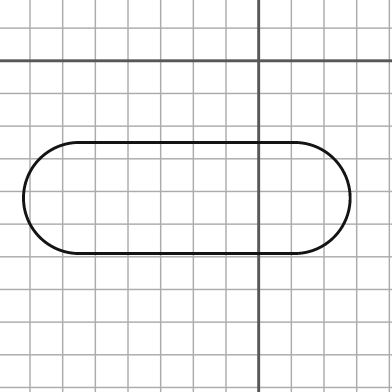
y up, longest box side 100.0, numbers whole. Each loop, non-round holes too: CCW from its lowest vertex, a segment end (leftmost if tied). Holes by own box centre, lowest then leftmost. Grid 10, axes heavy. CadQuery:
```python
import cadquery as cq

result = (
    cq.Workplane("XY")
    .moveTo(-55.0, -59.0)
    .lineTo(11.0, -59.0)
    .threePointArc((28.0, -42.0), (11.0, -25.0))
    .lineTo(-55.0, -25.0)
    .threePointArc((-72.0, -42.0), (-55.0, -59.0))
    .close()
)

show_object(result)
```